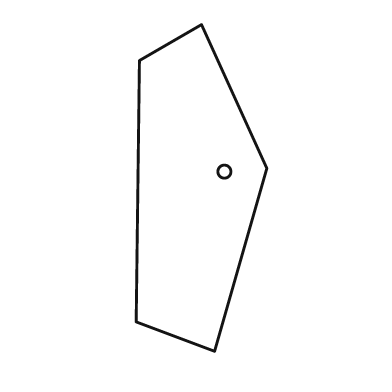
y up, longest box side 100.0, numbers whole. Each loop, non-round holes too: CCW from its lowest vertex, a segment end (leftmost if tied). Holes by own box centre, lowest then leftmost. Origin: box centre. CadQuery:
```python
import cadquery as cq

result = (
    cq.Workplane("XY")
    .moveTo(4.0, -50.0)
    .lineTo(20.0, 6.0)
    .lineTo(0.0, 50.0)
    .lineTo(-19.0, 39.0)
    .lineTo(-20.0, -41.0)
    .close()
    .moveTo(7.0, 5.0)
    .circle(2.0)
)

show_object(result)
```